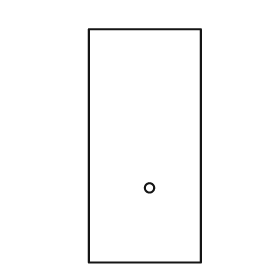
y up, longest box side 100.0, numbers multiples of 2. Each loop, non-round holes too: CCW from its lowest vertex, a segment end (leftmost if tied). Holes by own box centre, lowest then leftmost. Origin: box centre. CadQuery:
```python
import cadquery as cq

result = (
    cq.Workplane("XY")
    .moveTo(-24.0, -50.0)
    .lineTo(24.0, -50.0)
    .lineTo(24.0, 50.0)
    .lineTo(-24.0, 50.0)
    .close()
    .moveTo(2.0, -18.0)
    .circle(2.0)
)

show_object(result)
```